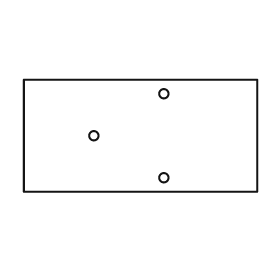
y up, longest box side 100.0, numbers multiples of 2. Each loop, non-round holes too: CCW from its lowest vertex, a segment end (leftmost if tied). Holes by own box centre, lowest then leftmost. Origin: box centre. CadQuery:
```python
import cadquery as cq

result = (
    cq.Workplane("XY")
    .moveTo(-50.0, -24.0)
    .lineTo(50.0, -24.0)
    .lineTo(50.0, 24.0)
    .lineTo(-50.0, 24.0)
    .close()
    .moveTo(10.0, -18.0)
    .circle(2.0)
    .moveTo(-20.0, 0.0)
    .circle(2.0)
    .moveTo(10.0, 18.0)
    .circle(2.0)
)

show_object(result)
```